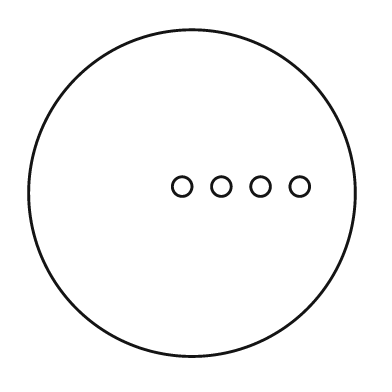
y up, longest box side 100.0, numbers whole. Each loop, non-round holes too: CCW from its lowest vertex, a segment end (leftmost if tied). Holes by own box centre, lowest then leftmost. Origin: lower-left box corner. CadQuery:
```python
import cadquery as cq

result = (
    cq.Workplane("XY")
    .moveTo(50.0, 50.0)
    .circle(50.0)
    .moveTo(47.0, 52.0)
    .circle(3.0)
    .moveTo(59.0, 52.0)
    .circle(3.0)
    .moveTo(71.0, 52.0)
    .circle(3.0)
    .moveTo(83.0, 52.0)
    .circle(3.0)
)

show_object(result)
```